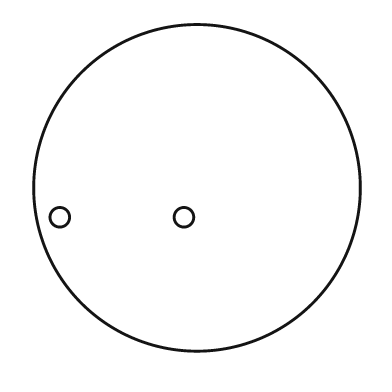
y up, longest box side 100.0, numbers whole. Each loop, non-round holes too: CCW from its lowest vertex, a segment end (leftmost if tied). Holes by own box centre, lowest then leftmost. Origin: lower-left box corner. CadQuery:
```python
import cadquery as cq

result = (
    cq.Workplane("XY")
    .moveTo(50.0, 50.0)
    .circle(50.0)
    .moveTo(8.0, 41.0)
    .circle(3.0)
    .moveTo(46.0, 41.0)
    .circle(3.0)
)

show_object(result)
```